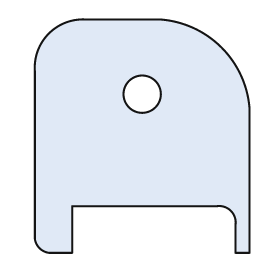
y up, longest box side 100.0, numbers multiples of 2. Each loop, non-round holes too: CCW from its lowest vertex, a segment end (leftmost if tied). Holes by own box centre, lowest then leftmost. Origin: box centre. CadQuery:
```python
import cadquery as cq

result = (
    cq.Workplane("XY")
    .moveTo(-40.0, -50.0)
    .lineTo(-30.0, -50.0)
    .lineTo(-30.0, -30.0)
    .lineTo(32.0, -30.0)
    .threePointArc((38.0, -32.0), (40.0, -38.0))
    .lineTo(40.0, -50.0)
    .lineTo(46.0, -50.0)
    .lineTo(46.0, 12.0)
    .threePointArc((34.0, 38.0), (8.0, 50.0))
    .lineTo(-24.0, 50.0)
    .threePointArc((-40.0, 44.0), (-46.0, 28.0))
    .lineTo(-46.0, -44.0)
    .threePointArc((-44.0, -48.0), (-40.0, -50.0))
    .close()
    .moveTo(0.0, 18.0)
    .circle(8.0)
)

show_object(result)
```